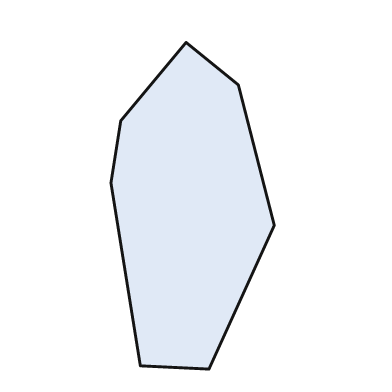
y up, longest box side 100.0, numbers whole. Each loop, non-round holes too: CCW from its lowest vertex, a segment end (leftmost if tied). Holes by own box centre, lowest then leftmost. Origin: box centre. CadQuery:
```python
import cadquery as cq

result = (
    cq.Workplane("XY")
    .moveTo(5.0, -50.0)
    .lineTo(25.0, -6.0)
    .lineTo(14.0, 37.0)
    .lineTo(-2.0, 50.0)
    .lineTo(-22.0, 26.0)
    .lineTo(-25.0, 7.0)
    .lineTo(-16.0, -49.0)
    .close()
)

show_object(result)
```